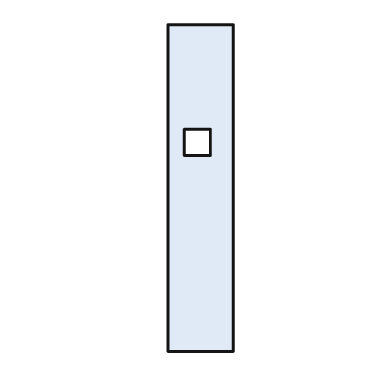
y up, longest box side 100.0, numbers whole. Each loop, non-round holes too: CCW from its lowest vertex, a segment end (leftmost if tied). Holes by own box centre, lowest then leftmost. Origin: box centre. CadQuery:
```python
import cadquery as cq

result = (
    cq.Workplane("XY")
    .moveTo(-10.0, -50.0)
    .lineTo(10.0, -50.0)
    .lineTo(10.0, 50.0)
    .lineTo(-10.0, 50.0)
    .close()
    .moveTo(-5.0, 10.0)
    .lineTo(3.0, 10.0)
    .lineTo(3.0, 18.0)
    .lineTo(-5.0, 18.0)
    .close()
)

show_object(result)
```